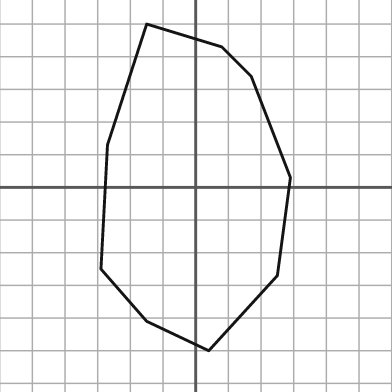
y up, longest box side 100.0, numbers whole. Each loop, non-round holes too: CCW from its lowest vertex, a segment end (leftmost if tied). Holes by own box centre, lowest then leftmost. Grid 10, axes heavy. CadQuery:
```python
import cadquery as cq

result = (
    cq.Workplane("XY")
    .moveTo(4.0, -50.0)
    .lineTo(25.0, -27.0)
    .lineTo(29.0, 3.0)
    .lineTo(17.0, 34.0)
    .lineTo(8.0, 43.0)
    .lineTo(-15.0, 50.0)
    .lineTo(-27.0, 13.0)
    .lineTo(-29.0, -25.0)
    .lineTo(-15.0, -41.0)
    .close()
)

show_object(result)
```